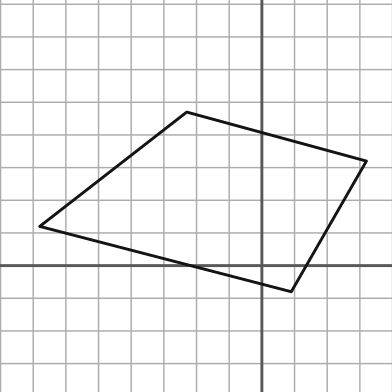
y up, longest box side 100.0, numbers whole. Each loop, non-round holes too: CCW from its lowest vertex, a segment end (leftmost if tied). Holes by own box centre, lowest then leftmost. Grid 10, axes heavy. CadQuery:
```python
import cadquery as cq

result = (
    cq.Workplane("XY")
    .moveTo(9.0, -8.0)
    .lineTo(32.0, 32.0)
    .lineTo(-23.0, 47.0)
    .lineTo(-68.0, 12.0)
    .close()
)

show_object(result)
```